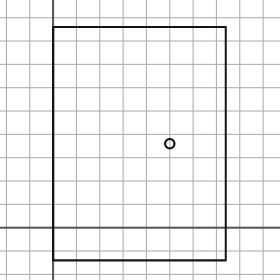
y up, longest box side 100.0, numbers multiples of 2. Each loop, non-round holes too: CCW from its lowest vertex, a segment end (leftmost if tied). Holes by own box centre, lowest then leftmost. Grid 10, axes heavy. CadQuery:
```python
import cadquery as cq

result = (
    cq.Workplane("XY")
    .moveTo(0.0, -14.0)
    .lineTo(74.0, -14.0)
    .lineTo(74.0, 86.0)
    .lineTo(0.0, 86.0)
    .close()
    .moveTo(50.0, 36.0)
    .circle(2.0)
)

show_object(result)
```